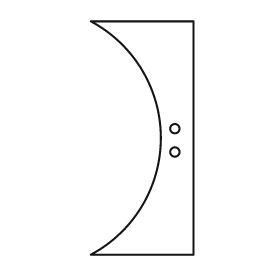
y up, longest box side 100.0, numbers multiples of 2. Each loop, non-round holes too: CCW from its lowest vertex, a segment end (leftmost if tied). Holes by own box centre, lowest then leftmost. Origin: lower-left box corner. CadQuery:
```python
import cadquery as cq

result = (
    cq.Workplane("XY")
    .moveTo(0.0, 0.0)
    .lineTo(44.0, 0.0)
    .lineTo(44.0, 100.0)
    .lineTo(0.0, 100.0)
    .threePointArc((30.0, 50.0), (0.0, 0.0))
    .close()
    .moveTo(36.0, 44.0)
    .circle(2.0)
    .moveTo(36.0, 54.0)
    .circle(2.0)
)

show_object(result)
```